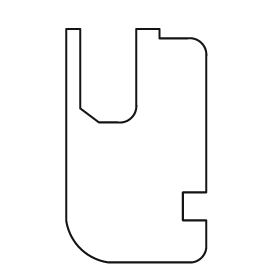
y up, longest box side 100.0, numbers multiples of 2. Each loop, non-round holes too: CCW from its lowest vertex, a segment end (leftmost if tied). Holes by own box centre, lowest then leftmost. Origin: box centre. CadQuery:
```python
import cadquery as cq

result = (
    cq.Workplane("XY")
    .moveTo(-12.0, -50.0)
    .lineTo(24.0, -50.0)
    .threePointArc((28.0, -48.0), (30.0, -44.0))
    .lineTo(30.0, -32.0)
    .lineTo(20.0, -32.0)
    .lineTo(20.0, -20.0)
    .lineTo(30.0, -20.0)
    .lineTo(30.0, 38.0)
    .threePointArc((28.0, 44.0), (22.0, 46.0))
    .lineTo(10.0, 46.0)
    .lineTo(10.0, 50.0)
    .lineTo(0.0, 50.0)
    .lineTo(0.0, 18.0)
    .threePointArc((-2.0, 12.0), (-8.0, 10.0))
    .lineTo(-16.0, 10.0)
    .lineTo(-24.0, 16.0)
    .lineTo(-24.0, 50.0)
    .lineTo(-30.0, 50.0)
    .lineTo(-30.0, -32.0)
    .threePointArc((-24.0, -44.0), (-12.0, -50.0))
    .close()
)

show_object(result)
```